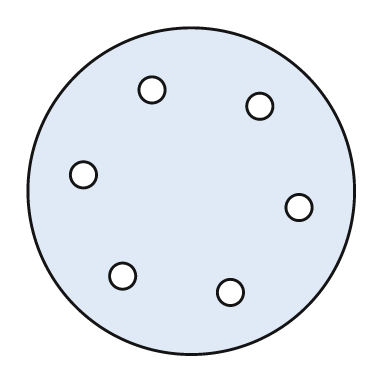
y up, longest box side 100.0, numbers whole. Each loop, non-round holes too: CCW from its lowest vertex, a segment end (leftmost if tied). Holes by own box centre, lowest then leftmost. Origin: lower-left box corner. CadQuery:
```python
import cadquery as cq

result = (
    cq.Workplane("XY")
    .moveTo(50.0, 50.0)
    .circle(50.0)
    .moveTo(62.0, 19.0)
    .circle(4.0)
    .moveTo(29.0, 24.0)
    .circle(4.0)
    .moveTo(83.0, 45.0)
    .circle(4.0)
    .moveTo(17.0, 55.0)
    .circle(4.0)
    .moveTo(71.0, 76.0)
    .circle(4.0)
    .moveTo(38.0, 81.0)
    .circle(4.0)
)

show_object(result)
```